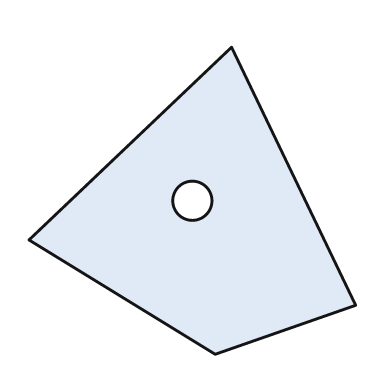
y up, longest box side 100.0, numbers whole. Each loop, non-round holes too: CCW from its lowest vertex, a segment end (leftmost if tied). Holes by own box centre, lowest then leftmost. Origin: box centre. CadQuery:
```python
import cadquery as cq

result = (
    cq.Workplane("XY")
    .moveTo(7.0, -47.0)
    .lineTo(50.0, -32.0)
    .lineTo(12.0, 47.0)
    .lineTo(-50.0, -12.0)
    .close()
    .moveTo(0.0, 0.0)
    .circle(6.0)
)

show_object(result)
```